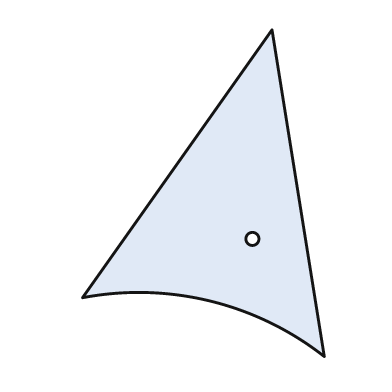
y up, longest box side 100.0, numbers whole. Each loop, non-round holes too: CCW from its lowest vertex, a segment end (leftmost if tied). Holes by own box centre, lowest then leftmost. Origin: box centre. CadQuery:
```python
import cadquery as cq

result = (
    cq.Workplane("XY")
    .moveTo(37.0, -50.0)
    .lineTo(21.0, 50.0)
    .lineTo(-37.0, -32.0)
    .threePointArc((2.0, -33.0), (37.0, -50.0))
    .close()
    .moveTo(15.0, -14.0)
    .circle(2.0)
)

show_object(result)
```